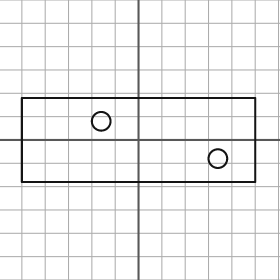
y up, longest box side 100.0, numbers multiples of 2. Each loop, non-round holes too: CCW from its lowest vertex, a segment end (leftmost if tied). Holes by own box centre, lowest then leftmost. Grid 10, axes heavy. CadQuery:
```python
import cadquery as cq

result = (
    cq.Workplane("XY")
    .moveTo(-50.0, -18.0)
    .lineTo(50.0, -18.0)
    .lineTo(50.0, 18.0)
    .lineTo(-50.0, 18.0)
    .close()
    .moveTo(34.0, -8.0)
    .circle(4.0)
    .moveTo(-16.0, 8.0)
    .circle(4.0)
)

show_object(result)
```